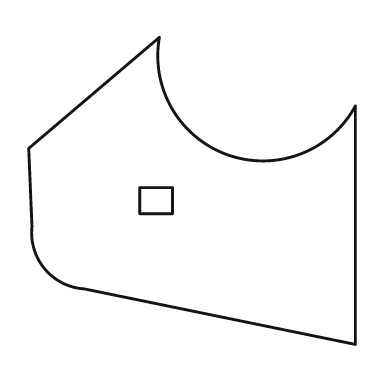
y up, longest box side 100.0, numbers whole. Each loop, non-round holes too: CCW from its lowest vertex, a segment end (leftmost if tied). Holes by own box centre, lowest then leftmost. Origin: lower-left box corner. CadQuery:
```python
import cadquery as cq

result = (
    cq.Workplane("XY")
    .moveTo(100.0, 0.0)
    .lineTo(100.0, 73.0)
    .threePointArc((61.0, 58.0), (40.0, 94.0))
    .lineTo(0.0, 60.0)
    .lineTo(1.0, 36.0)
    .threePointArc((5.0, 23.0), (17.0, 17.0))
    .close()
    .moveTo(34.0, 40.0)
    .lineTo(44.0, 40.0)
    .lineTo(44.0, 48.0)
    .lineTo(34.0, 48.0)
    .close()
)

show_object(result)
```